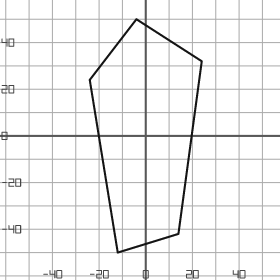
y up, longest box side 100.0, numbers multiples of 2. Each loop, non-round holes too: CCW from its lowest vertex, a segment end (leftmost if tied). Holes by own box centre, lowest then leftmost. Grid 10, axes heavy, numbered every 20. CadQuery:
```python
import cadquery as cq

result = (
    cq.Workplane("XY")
    .moveTo(-12.0, -50.0)
    .lineTo(14.0, -42.0)
    .lineTo(24.0, 32.0)
    .lineTo(-4.0, 50.0)
    .lineTo(-24.0, 24.0)
    .close()
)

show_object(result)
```